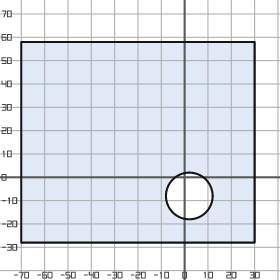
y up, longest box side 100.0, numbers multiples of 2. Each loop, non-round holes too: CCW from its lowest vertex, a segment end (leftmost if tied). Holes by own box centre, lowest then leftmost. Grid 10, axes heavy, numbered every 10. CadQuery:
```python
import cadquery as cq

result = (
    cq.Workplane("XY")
    .moveTo(-70.0, -28.0)
    .lineTo(30.0, -28.0)
    .lineTo(30.0, 58.0)
    .lineTo(-70.0, 58.0)
    .close()
    .moveTo(2.0, -8.0)
    .circle(10.0)
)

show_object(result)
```